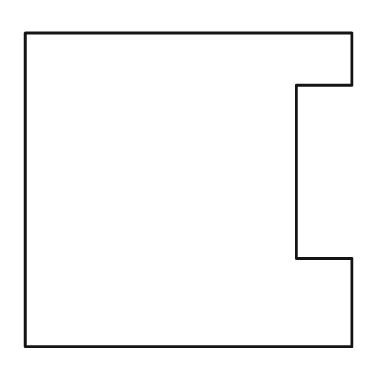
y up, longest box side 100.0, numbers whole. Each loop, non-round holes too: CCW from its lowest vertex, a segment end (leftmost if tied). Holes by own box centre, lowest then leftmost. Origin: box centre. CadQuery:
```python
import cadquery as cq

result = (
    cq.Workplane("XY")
    .moveTo(-50.0, -48.0)
    .lineTo(50.0, -48.0)
    .lineTo(50.0, -21.0)
    .lineTo(33.0, -21.0)
    .lineTo(33.0, 32.0)
    .lineTo(50.0, 32.0)
    .lineTo(50.0, 48.0)
    .lineTo(-50.0, 48.0)
    .close()
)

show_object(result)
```